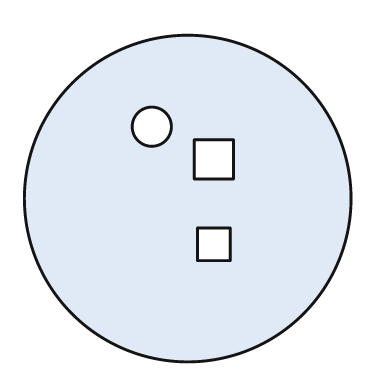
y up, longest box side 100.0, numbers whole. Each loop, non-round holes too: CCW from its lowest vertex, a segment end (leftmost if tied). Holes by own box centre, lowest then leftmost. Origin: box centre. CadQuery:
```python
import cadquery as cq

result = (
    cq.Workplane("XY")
    .moveTo(0.0, 0.0)
    .circle(50.0)
    .moveTo(3.0, -19.0)
    .lineTo(13.0, -19.0)
    .lineTo(13.0, -9.0)
    .lineTo(3.0, -9.0)
    .close()
    .moveTo(2.0, 6.0)
    .lineTo(14.0, 6.0)
    .lineTo(14.0, 18.0)
    .lineTo(2.0, 18.0)
    .close()
    .moveTo(-11.0, 22.0)
    .circle(6.0)
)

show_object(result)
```